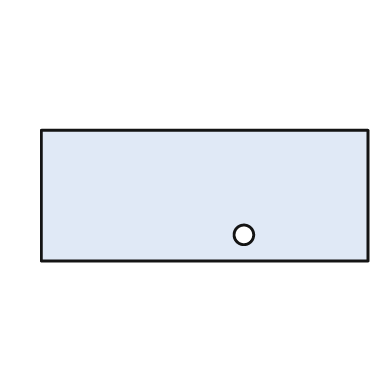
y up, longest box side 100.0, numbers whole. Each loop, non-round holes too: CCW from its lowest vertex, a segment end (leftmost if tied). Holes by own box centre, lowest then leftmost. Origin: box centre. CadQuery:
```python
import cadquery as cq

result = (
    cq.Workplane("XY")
    .moveTo(-50.0, -20.0)
    .lineTo(50.0, -20.0)
    .lineTo(50.0, 20.0)
    .lineTo(-50.0, 20.0)
    .close()
    .moveTo(12.0, -12.0)
    .circle(3.0)
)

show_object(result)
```